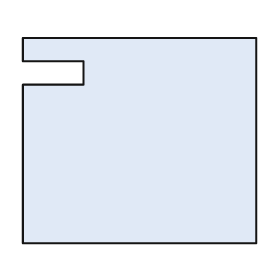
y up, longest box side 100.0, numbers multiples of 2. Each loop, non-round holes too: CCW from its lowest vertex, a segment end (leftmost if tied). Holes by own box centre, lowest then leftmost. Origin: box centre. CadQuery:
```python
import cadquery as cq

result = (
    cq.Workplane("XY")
    .moveTo(-50.0, -44.0)
    .lineTo(50.0, -44.0)
    .lineTo(50.0, 44.0)
    .lineTo(-50.0, 44.0)
    .lineTo(-50.0, 34.0)
    .lineTo(-24.0, 34.0)
    .lineTo(-24.0, 24.0)
    .lineTo(-50.0, 24.0)
    .close()
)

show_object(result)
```